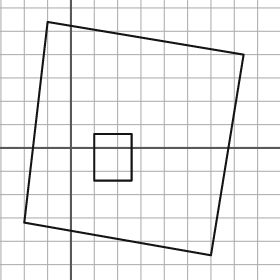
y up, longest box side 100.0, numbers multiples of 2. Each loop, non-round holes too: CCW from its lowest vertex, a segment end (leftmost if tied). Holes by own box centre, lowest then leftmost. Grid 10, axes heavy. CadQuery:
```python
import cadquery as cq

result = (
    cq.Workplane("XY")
    .moveTo(60.0, -46.0)
    .lineTo(74.0, 40.0)
    .lineTo(-10.0, 54.0)
    .lineTo(-20.0, -32.0)
    .close()
    .moveTo(10.0, -14.0)
    .lineTo(26.0, -14.0)
    .lineTo(26.0, 6.0)
    .lineTo(10.0, 6.0)
    .close()
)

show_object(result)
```